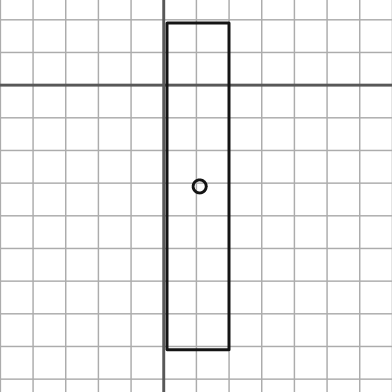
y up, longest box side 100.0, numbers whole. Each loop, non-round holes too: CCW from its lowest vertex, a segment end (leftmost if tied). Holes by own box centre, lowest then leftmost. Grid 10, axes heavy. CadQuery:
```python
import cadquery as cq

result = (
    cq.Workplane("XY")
    .moveTo(1.0, -81.0)
    .lineTo(20.0, -81.0)
    .lineTo(20.0, 19.0)
    .lineTo(1.0, 19.0)
    .close()
    .moveTo(11.0, -31.0)
    .circle(2.0)
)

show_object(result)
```